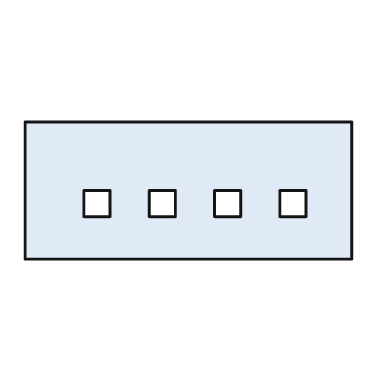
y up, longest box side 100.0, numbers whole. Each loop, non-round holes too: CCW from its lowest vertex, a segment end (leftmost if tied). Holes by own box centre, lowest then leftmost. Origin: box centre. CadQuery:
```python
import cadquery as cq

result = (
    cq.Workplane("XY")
    .moveTo(-50.0, -21.0)
    .lineTo(50.0, -21.0)
    .lineTo(50.0, 21.0)
    .lineTo(-50.0, 21.0)
    .close()
    .moveTo(-32.0, -8.0)
    .lineTo(-24.0, -8.0)
    .lineTo(-24.0, 0.0)
    .lineTo(-32.0, 0.0)
    .close()
    .moveTo(-12.0, -8.0)
    .lineTo(-4.0, -8.0)
    .lineTo(-4.0, 0.0)
    .lineTo(-12.0, 0.0)
    .close()
    .moveTo(8.0, -8.0)
    .lineTo(16.0, -8.0)
    .lineTo(16.0, 0.0)
    .lineTo(8.0, 0.0)
    .close()
    .moveTo(28.0, -8.0)
    .lineTo(36.0, -8.0)
    .lineTo(36.0, 0.0)
    .lineTo(28.0, 0.0)
    .close()
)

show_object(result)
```